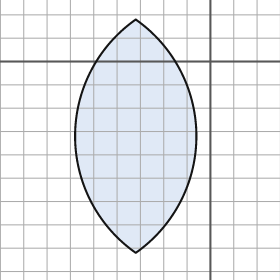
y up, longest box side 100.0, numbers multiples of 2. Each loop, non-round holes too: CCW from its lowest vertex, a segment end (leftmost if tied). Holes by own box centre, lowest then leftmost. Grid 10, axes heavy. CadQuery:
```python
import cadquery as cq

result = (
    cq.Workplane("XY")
    .moveTo(-32.0, -82.0)
    .threePointArc((-6.0, -32.0), (-32.0, 18.0))
    .threePointArc((-58.0, -32.0), (-32.0, -82.0))
    .close()
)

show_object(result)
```